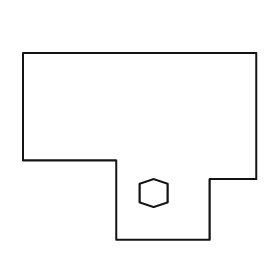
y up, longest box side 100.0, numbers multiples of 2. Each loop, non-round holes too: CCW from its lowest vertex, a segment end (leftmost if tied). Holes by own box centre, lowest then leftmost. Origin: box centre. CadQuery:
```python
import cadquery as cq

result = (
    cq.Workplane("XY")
    .moveTo(-10.0, -40.0)
    .lineTo(30.0, -40.0)
    .lineTo(30.0, -14.0)
    .lineTo(50.0, -14.0)
    .lineTo(50.0, 40.0)
    .lineTo(-50.0, 40.0)
    .lineTo(-50.0, -6.0)
    .lineTo(-10.0, -6.0)
    .close()
    .moveTo(6.0, -26.0)
    .lineTo(12.0, -24.0)
    .lineTo(12.0, -16.0)
    .lineTo(6.0, -14.0)
    .lineTo(0.0, -16.0)
    .lineTo(0.0, -24.0)
    .close()
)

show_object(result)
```